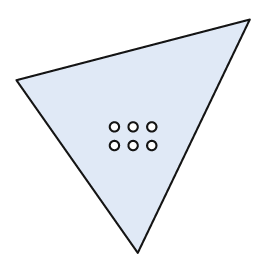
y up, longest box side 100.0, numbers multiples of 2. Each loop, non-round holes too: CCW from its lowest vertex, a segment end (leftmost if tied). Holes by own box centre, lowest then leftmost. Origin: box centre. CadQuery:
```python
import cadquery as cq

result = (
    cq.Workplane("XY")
    .moveTo(2.0, -50.0)
    .lineTo(50.0, 50.0)
    .lineTo(-50.0, 24.0)
    .close()
    .moveTo(-8.0, -4.0)
    .circle(2.0)
    .moveTo(0.0, -4.0)
    .circle(2.0)
    .moveTo(8.0, -4.0)
    .circle(2.0)
    .moveTo(-8.0, 4.0)
    .circle(2.0)
    .moveTo(0.0, 4.0)
    .circle(2.0)
    .moveTo(8.0, 4.0)
    .circle(2.0)
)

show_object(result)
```